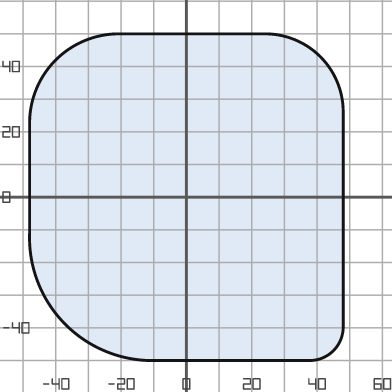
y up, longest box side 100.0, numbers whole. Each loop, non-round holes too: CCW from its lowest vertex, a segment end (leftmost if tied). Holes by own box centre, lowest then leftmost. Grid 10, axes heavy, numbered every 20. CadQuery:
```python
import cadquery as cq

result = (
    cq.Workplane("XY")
    .moveTo(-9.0, -50.0)
    .lineTo(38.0, -50.0)
    .threePointArc((45.0, -47.0), (48.0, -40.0))
    .lineTo(48.0, 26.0)
    .threePointArc((41.0, 43.0), (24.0, 50.0))
    .lineTo(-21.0, 50.0)
    .threePointArc((-40.0, 42.0), (-48.0, 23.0))
    .lineTo(-48.0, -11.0)
    .threePointArc((-37.0, -39.0), (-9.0, -50.0))
    .close()
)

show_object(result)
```